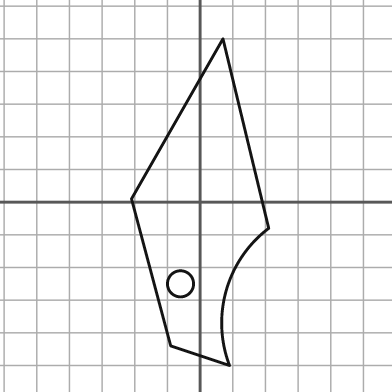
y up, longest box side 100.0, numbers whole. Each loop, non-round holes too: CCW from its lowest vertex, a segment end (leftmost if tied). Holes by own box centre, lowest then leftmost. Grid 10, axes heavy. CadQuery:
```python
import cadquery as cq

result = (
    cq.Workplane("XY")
    .moveTo(9.0, -50.0)
    .threePointArc((8.0, -27.0), (21.0, -8.0))
    .lineTo(7.0, 50.0)
    .lineTo(-21.0, 1.0)
    .lineTo(-9.0, -44.0)
    .close()
    .moveTo(-6.0, -25.0)
    .circle(4.0)
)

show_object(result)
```